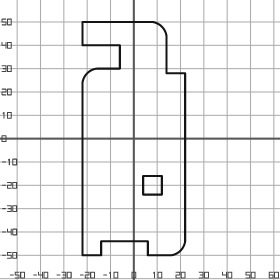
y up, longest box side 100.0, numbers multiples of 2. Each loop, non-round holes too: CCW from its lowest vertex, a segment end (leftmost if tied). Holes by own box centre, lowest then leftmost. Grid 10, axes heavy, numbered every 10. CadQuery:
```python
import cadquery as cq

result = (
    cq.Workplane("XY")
    .moveTo(-22.0, -50.0)
    .lineTo(-14.0, -50.0)
    .lineTo(-14.0, -44.0)
    .lineTo(6.0, -44.0)
    .lineTo(6.0, -50.0)
    .lineTo(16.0, -50.0)
    .threePointArc((20.0, -48.0), (22.0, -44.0))
    .lineTo(22.0, 28.0)
    .lineTo(14.0, 28.0)
    .lineTo(14.0, 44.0)
    .threePointArc((12.0, 48.0), (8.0, 50.0))
    .lineTo(-22.0, 50.0)
    .lineTo(-22.0, 40.0)
    .lineTo(-6.0, 40.0)
    .lineTo(-6.0, 30.0)
    .lineTo(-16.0, 30.0)
    .threePointArc((-20.0, 28.0), (-22.0, 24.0))
    .close()
    .moveTo(4.0, -24.0)
    .lineTo(12.0, -24.0)
    .lineTo(12.0, -16.0)
    .lineTo(4.0, -16.0)
    .close()
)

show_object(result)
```